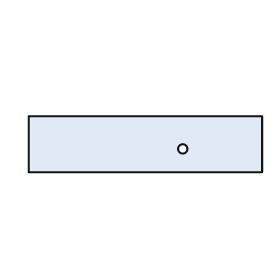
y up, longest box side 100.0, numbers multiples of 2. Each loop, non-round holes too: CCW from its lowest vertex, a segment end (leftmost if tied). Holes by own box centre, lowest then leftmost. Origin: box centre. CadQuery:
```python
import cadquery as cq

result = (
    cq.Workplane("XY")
    .moveTo(-50.0, -12.0)
    .lineTo(50.0, -12.0)
    .lineTo(50.0, 12.0)
    .lineTo(-50.0, 12.0)
    .close()
    .moveTo(16.0, -2.0)
    .circle(2.0)
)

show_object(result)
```